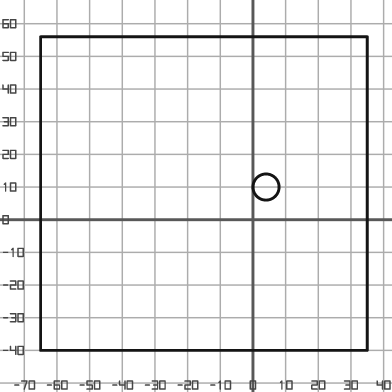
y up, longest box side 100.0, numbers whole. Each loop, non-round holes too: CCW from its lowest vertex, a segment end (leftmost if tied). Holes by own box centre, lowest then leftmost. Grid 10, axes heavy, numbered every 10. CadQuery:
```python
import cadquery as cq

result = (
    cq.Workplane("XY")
    .moveTo(-65.0, -40.0)
    .lineTo(35.0, -40.0)
    .lineTo(35.0, 56.0)
    .lineTo(-65.0, 56.0)
    .close()
    .moveTo(4.0, 10.0)
    .circle(4.0)
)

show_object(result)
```